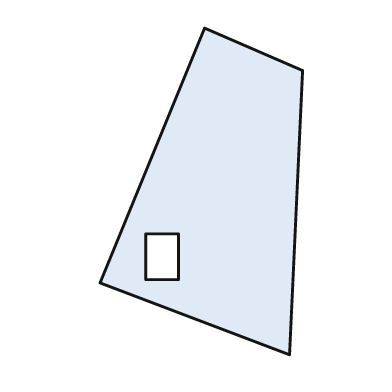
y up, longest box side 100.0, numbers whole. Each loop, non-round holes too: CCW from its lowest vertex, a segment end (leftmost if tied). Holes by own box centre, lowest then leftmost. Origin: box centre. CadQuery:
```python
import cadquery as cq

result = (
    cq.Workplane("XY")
    .moveTo(27.0, -50.0)
    .lineTo(31.0, 37.0)
    .lineTo(1.0, 50.0)
    .lineTo(-31.0, -28.0)
    .close()
    .moveTo(-17.0, -27.0)
    .lineTo(-7.0, -27.0)
    .lineTo(-7.0, -13.0)
    .lineTo(-17.0, -13.0)
    .close()
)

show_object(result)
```